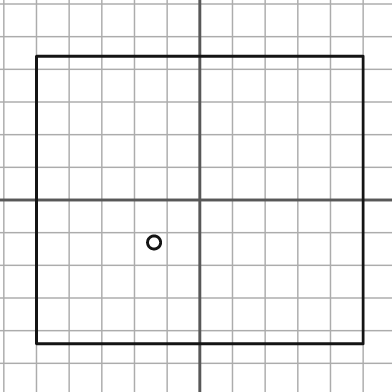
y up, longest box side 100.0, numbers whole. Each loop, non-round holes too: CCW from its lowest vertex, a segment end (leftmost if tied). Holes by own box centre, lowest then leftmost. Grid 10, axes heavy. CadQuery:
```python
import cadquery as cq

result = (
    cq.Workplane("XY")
    .moveTo(-50.0, -44.0)
    .lineTo(50.0, -44.0)
    .lineTo(50.0, 44.0)
    .lineTo(-50.0, 44.0)
    .close()
    .moveTo(-14.0, -13.0)
    .circle(2.0)
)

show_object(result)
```